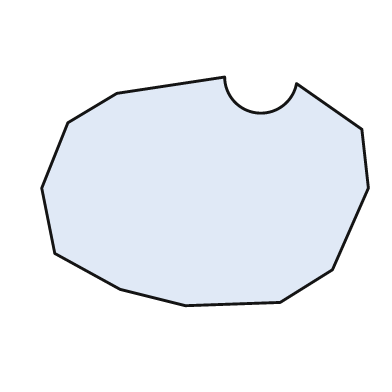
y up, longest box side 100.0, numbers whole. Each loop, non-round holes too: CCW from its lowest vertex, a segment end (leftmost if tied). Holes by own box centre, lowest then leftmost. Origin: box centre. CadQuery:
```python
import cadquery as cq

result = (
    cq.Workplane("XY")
    .moveTo(-6.0, -35.0)
    .lineTo(23.0, -34.0)
    .lineTo(39.0, -24.0)
    .lineTo(50.0, 1.0)
    .lineTo(48.0, 19.0)
    .lineTo(28.0, 33.0)
    .threePointArc((16.0, 24.0), (6.0, 35.0))
    .lineTo(-27.0, 30.0)
    .lineTo(-42.0, 21.0)
    .lineTo(-50.0, 1.0)
    .lineTo(-46.0, -19.0)
    .lineTo(-26.0, -30.0)
    .close()
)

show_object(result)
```